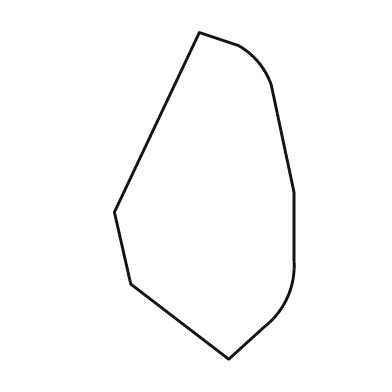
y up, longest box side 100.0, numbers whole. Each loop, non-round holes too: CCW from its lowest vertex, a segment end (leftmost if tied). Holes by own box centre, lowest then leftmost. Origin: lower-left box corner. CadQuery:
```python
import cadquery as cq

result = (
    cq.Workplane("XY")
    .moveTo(35.0, 0.0)
    .lineTo(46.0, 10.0)
    .threePointArc((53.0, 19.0), (55.0, 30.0))
    .lineTo(55.0, 51.0)
    .lineTo(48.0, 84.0)
    .threePointArc((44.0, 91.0), (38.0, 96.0))
    .lineTo(26.0, 100.0)
    .lineTo(0.0, 45.0)
    .lineTo(5.0, 23.0)
    .close()
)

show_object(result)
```